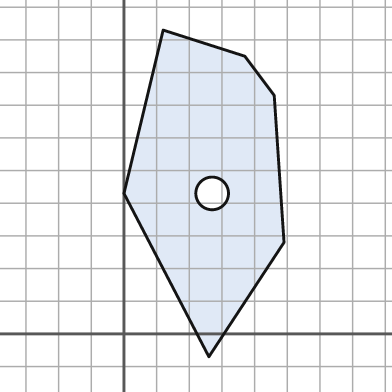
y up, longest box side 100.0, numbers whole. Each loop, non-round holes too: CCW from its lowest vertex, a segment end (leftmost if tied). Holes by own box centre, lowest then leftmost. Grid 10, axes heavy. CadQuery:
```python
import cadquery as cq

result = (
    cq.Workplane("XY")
    .moveTo(26.0, -7.0)
    .lineTo(49.0, 28.0)
    .lineTo(46.0, 73.0)
    .lineTo(37.0, 85.0)
    .lineTo(12.0, 93.0)
    .lineTo(0.0, 43.0)
    .close()
    .moveTo(27.0, 43.0)
    .circle(5.0)
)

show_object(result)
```